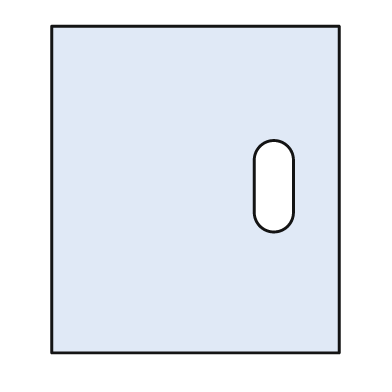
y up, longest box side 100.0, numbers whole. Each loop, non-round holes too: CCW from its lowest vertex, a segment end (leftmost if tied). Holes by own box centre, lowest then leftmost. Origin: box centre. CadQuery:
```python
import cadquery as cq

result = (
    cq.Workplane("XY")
    .moveTo(-44.0, -50.0)
    .lineTo(44.0, -50.0)
    .lineTo(44.0, 50.0)
    .lineTo(-44.0, 50.0)
    .close()
    .moveTo(18.0, -7.0)
    .threePointArc((24.0, -13.0), (30.0, -7.0))
    .lineTo(30.0, 9.0)
    .threePointArc((24.0, 15.0), (18.0, 9.0))
    .close()
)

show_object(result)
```